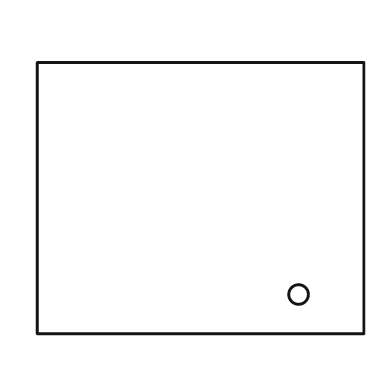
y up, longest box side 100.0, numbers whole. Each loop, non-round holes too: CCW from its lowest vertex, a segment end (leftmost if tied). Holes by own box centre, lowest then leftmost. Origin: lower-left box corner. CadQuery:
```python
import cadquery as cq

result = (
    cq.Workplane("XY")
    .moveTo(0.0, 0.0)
    .lineTo(100.0, 0.0)
    .lineTo(100.0, 83.0)
    .lineTo(0.0, 83.0)
    .close()
    .moveTo(80.0, 12.0)
    .circle(3.0)
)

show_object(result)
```